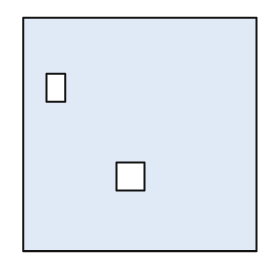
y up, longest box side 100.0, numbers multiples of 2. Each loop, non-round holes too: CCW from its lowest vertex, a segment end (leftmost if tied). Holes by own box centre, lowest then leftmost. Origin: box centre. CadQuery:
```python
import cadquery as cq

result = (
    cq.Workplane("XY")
    .moveTo(-50.0, -50.0)
    .lineTo(50.0, -50.0)
    .lineTo(50.0, 50.0)
    .lineTo(-50.0, 50.0)
    .close()
    .moveTo(-10.0, -24.0)
    .lineTo(2.0, -24.0)
    .lineTo(2.0, -12.0)
    .lineTo(-10.0, -12.0)
    .close()
    .moveTo(-40.0, 14.0)
    .lineTo(-32.0, 14.0)
    .lineTo(-32.0, 26.0)
    .lineTo(-40.0, 26.0)
    .close()
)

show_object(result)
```